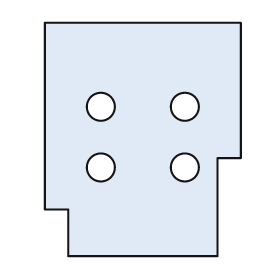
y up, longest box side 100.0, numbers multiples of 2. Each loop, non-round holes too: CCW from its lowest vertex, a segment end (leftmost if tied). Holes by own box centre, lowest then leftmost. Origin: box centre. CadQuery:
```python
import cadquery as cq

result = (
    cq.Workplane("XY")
    .moveTo(-32.0, -50.0)
    .lineTo(32.0, -50.0)
    .lineTo(32.0, -8.0)
    .lineTo(42.0, -8.0)
    .lineTo(42.0, 50.0)
    .lineTo(-42.0, 50.0)
    .lineTo(-42.0, -30.0)
    .lineTo(-32.0, -30.0)
    .close()
    .moveTo(-18.0, -12.0)
    .circle(6.0)
    .moveTo(18.0, -12.0)
    .circle(6.0)
    .moveTo(-18.0, 14.0)
    .circle(6.0)
    .moveTo(18.0, 14.0)
    .circle(6.0)
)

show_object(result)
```